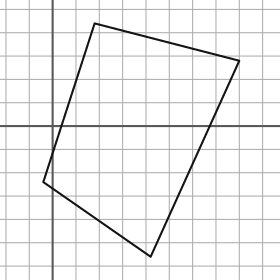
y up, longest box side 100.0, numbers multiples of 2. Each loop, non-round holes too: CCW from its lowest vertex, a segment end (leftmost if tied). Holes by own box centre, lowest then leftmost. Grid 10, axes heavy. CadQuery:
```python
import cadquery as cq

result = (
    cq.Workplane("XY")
    .moveTo(42.0, -56.0)
    .lineTo(80.0, 28.0)
    .lineTo(18.0, 44.0)
    .lineTo(-4.0, -24.0)
    .close()
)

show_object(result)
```